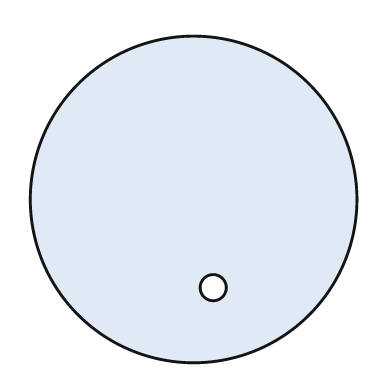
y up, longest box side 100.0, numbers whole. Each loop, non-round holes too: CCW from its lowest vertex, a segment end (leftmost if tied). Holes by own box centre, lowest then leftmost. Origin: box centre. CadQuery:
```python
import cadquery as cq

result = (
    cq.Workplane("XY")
    .moveTo(0.0, 0.0)
    .circle(50.0)
    .moveTo(6.0, -27.0)
    .circle(4.0)
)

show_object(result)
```